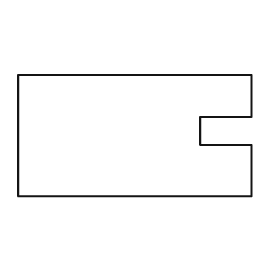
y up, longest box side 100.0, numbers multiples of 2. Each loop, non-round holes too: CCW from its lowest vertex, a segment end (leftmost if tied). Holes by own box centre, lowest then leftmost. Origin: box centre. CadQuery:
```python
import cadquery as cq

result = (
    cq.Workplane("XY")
    .moveTo(-50.0, -26.0)
    .lineTo(50.0, -26.0)
    .lineTo(50.0, -4.0)
    .lineTo(28.0, -4.0)
    .lineTo(28.0, 8.0)
    .lineTo(50.0, 8.0)
    .lineTo(50.0, 26.0)
    .lineTo(-50.0, 26.0)
    .close()
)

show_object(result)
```